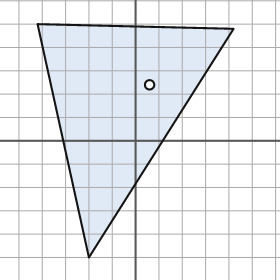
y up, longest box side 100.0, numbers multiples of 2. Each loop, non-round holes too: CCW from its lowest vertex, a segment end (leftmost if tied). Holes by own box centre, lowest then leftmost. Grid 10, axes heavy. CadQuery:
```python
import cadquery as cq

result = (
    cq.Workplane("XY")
    .moveTo(-20.0, -50.0)
    .lineTo(42.0, 48.0)
    .lineTo(-42.0, 50.0)
    .close()
    .moveTo(6.0, 24.0)
    .circle(2.0)
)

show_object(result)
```